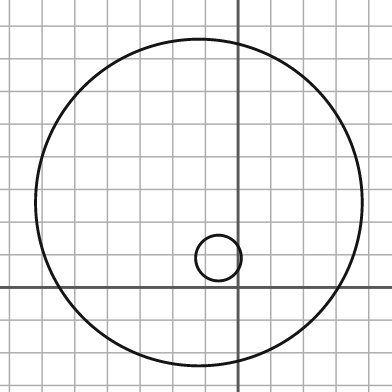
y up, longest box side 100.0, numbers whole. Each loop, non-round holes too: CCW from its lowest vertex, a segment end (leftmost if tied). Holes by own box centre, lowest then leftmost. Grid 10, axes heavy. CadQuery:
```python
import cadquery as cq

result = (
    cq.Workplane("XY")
    .moveTo(-12.0, 26.0)
    .circle(50.0)
    .moveTo(-6.0, 9.0)
    .circle(7.0)
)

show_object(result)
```